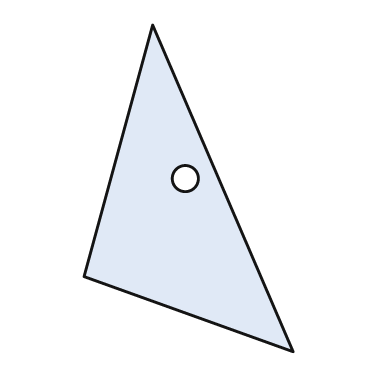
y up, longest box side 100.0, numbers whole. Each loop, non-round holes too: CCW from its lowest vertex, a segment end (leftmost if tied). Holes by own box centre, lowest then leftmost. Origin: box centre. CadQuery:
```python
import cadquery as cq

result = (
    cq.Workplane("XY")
    .moveTo(32.0, -50.0)
    .lineTo(-11.0, 50.0)
    .lineTo(-32.0, -27.0)
    .close()
    .moveTo(-1.0, 3.0)
    .circle(4.0)
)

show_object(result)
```